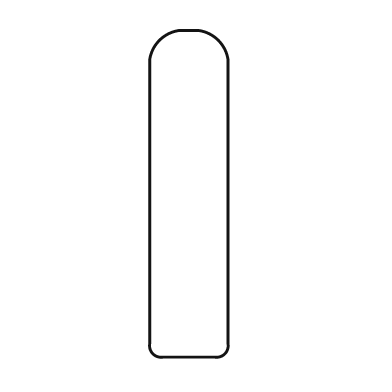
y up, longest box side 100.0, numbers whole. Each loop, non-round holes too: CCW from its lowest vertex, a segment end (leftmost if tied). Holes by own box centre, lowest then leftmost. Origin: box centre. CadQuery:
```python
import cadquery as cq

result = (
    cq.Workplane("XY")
    .moveTo(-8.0, -50.0)
    .lineTo(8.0, -50.0)
    .threePointArc((11.0, -49.0), (12.0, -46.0))
    .lineTo(12.0, 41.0)
    .threePointArc((9.0, 47.0), (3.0, 50.0))
    .lineTo(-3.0, 50.0)
    .threePointArc((-9.0, 47.0), (-12.0, 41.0))
    .lineTo(-12.0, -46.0)
    .threePointArc((-11.0, -49.0), (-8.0, -50.0))
    .close()
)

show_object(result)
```